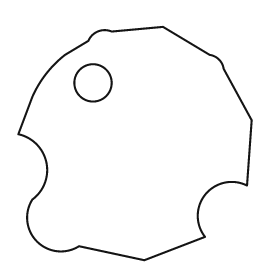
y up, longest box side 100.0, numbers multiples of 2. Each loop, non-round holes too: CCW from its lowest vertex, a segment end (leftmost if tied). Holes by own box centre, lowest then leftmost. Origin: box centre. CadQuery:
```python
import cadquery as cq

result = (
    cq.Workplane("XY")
    .moveTo(4.0, -50.0)
    .lineTo(30.0, -40.0)
    .threePointArc((30.0, -22.0), (48.0, -18.0))
    .lineTo(50.0, 10.0)
    .lineTo(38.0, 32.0)
    .threePointArc((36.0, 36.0), (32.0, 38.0))
    .lineTo(12.0, 50.0)
    .lineTo(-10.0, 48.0)
    .threePointArc((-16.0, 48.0), (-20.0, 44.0))
    .lineTo(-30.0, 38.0)
    .threePointArc((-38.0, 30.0), (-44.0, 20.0))
    .lineTo(-50.0, 4.0)
    .threePointArc((-38.0, -8.0), (-44.0, -24.0))
    .threePointArc((-42.0, -42.0), (-24.0, -44.0))
    .close()
    .moveTo(-18.0, 26.0)
    .circle(8.0)
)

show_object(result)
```